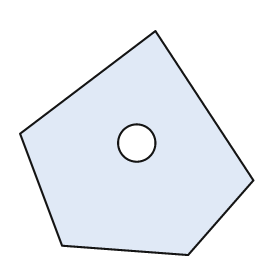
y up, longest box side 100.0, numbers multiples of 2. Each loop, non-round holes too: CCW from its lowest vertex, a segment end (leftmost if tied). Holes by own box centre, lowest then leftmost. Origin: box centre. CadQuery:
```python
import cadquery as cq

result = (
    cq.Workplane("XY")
    .moveTo(22.0, -48.0)
    .lineTo(50.0, -16.0)
    .lineTo(8.0, 48.0)
    .lineTo(-50.0, 4.0)
    .lineTo(-32.0, -44.0)
    .close()
    .moveTo(0.0, 0.0)
    .circle(8.0)
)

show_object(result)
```